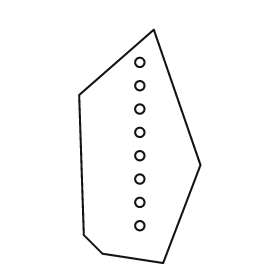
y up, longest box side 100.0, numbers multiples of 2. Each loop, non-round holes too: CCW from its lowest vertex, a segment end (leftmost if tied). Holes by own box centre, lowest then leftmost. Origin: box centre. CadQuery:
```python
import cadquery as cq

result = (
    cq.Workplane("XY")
    .moveTo(10.0, -50.0)
    .lineTo(26.0, -8.0)
    .lineTo(6.0, 50.0)
    .lineTo(-26.0, 22.0)
    .lineTo(-24.0, -38.0)
    .lineTo(-16.0, -46.0)
    .close()
    .moveTo(0.0, -34.0)
    .circle(2.0)
    .moveTo(0.0, -24.0)
    .circle(2.0)
    .moveTo(0.0, -14.0)
    .circle(2.0)
    .moveTo(0.0, -4.0)
    .circle(2.0)
    .moveTo(0.0, 6.0)
    .circle(2.0)
    .moveTo(0.0, 16.0)
    .circle(2.0)
    .moveTo(0.0, 26.0)
    .circle(2.0)
    .moveTo(0.0, 36.0)
    .circle(2.0)
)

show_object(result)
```